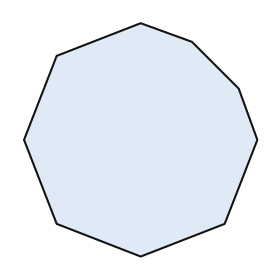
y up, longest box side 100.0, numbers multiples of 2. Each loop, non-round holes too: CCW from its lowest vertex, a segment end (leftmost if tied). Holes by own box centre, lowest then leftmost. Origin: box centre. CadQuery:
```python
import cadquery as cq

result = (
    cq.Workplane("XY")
    .moveTo(0.0, -50.0)
    .lineTo(36.0, -36.0)
    .lineTo(50.0, 0.0)
    .lineTo(42.0, 22.0)
    .lineTo(22.0, 42.0)
    .lineTo(0.0, 50.0)
    .lineTo(-36.0, 36.0)
    .lineTo(-50.0, 0.0)
    .lineTo(-36.0, -36.0)
    .close()
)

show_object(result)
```